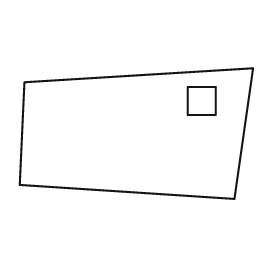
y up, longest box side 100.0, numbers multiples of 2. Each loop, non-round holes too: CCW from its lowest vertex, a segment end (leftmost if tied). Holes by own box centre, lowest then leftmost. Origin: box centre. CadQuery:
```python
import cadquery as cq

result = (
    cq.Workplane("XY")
    .moveTo(42.0, -28.0)
    .lineTo(50.0, 28.0)
    .lineTo(-48.0, 22.0)
    .lineTo(-50.0, -22.0)
    .close()
    .moveTo(22.0, 8.0)
    .lineTo(34.0, 8.0)
    .lineTo(34.0, 20.0)
    .lineTo(22.0, 20.0)
    .close()
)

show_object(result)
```